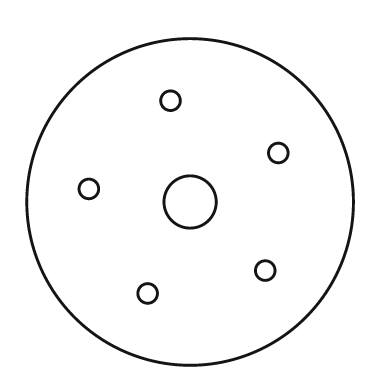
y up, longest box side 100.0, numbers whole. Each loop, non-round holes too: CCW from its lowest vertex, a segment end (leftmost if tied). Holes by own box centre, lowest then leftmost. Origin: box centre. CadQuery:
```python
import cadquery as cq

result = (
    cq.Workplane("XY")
    .moveTo(0.0, 0.0)
    .circle(50.0)
    .moveTo(-13.0, -28.0)
    .circle(3.0)
    .moveTo(23.0, -21.0)
    .circle(3.0)
    .moveTo(0.0, 0.0)
    .circle(8.0)
    .moveTo(-31.0, 4.0)
    .circle(3.0)
    .moveTo(27.0, 15.0)
    .circle(3.0)
    .moveTo(-6.0, 31.0)
    .circle(3.0)
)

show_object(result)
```